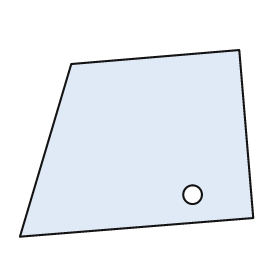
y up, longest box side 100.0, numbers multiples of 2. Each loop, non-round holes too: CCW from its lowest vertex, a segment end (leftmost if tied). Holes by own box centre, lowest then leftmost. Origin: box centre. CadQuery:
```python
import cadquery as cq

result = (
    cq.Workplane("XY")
    .moveTo(-50.0, -40.0)
    .lineTo(50.0, -32.0)
    .lineTo(44.0, 40.0)
    .lineTo(-28.0, 34.0)
    .close()
    .moveTo(24.0, -22.0)
    .circle(4.0)
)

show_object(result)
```